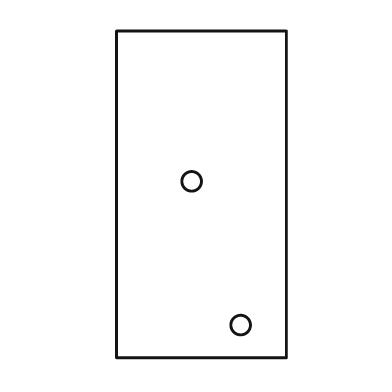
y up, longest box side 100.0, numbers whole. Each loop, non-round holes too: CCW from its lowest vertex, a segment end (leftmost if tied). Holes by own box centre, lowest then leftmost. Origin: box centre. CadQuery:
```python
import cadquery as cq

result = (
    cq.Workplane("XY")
    .moveTo(-26.0, -50.0)
    .lineTo(26.0, -50.0)
    .lineTo(26.0, 50.0)
    .lineTo(-26.0, 50.0)
    .close()
    .moveTo(12.0, -40.0)
    .circle(3.0)
    .moveTo(-3.0, 4.0)
    .circle(3.0)
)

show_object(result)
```